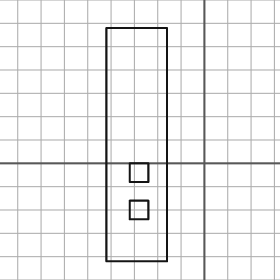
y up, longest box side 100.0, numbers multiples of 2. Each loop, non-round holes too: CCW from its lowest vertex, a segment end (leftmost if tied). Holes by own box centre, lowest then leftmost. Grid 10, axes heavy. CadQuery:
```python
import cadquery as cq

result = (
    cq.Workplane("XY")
    .moveTo(-42.0, -42.0)
    .lineTo(-16.0, -42.0)
    .lineTo(-16.0, 58.0)
    .lineTo(-42.0, 58.0)
    .close()
    .moveTo(-32.0, -24.0)
    .lineTo(-24.0, -24.0)
    .lineTo(-24.0, -16.0)
    .lineTo(-32.0, -16.0)
    .close()
    .moveTo(-32.0, -8.0)
    .lineTo(-24.0, -8.0)
    .lineTo(-24.0, 0.0)
    .lineTo(-32.0, 0.0)
    .close()
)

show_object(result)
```